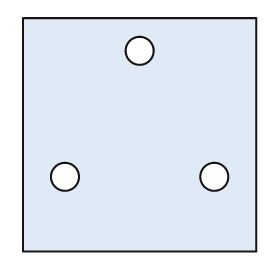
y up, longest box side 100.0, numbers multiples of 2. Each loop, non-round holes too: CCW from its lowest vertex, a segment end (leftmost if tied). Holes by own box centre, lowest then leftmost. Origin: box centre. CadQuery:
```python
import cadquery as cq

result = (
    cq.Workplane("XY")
    .moveTo(-50.0, -50.0)
    .lineTo(50.0, -50.0)
    .lineTo(50.0, 50.0)
    .lineTo(-50.0, 50.0)
    .close()
    .moveTo(-32.0, -18.0)
    .circle(6.0)
    .moveTo(32.0, -18.0)
    .circle(6.0)
    .moveTo(0.0, 36.0)
    .circle(6.0)
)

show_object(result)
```